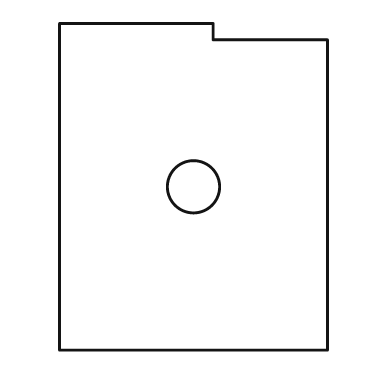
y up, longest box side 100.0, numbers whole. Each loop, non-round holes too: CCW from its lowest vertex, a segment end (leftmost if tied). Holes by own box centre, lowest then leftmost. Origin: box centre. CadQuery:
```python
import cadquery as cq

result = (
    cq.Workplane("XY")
    .moveTo(-41.0, -50.0)
    .lineTo(41.0, -50.0)
    .lineTo(41.0, 45.0)
    .lineTo(6.0, 45.0)
    .lineTo(6.0, 50.0)
    .lineTo(-41.0, 50.0)
    .close()
    .moveTo(0.0, 0.0)
    .circle(8.0)
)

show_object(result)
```